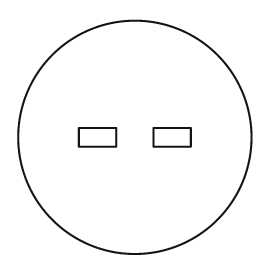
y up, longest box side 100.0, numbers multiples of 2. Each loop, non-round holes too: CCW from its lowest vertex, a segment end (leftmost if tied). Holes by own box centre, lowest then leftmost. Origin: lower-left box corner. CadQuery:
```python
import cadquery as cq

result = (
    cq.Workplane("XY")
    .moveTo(50.0, 50.0)
    .circle(50.0)
    .moveTo(26.0, 46.0)
    .lineTo(42.0, 46.0)
    .lineTo(42.0, 54.0)
    .lineTo(26.0, 54.0)
    .close()
    .moveTo(58.0, 46.0)
    .lineTo(74.0, 46.0)
    .lineTo(74.0, 54.0)
    .lineTo(58.0, 54.0)
    .close()
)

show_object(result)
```